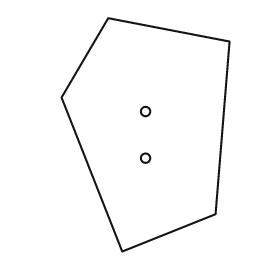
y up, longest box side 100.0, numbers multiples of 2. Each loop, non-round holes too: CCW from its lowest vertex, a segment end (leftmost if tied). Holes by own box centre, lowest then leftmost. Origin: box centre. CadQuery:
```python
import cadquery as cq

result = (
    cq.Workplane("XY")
    .moveTo(-10.0, -50.0)
    .lineTo(30.0, -34.0)
    .lineTo(36.0, 40.0)
    .lineTo(-16.0, 50.0)
    .lineTo(-36.0, 16.0)
    .close()
    .moveTo(0.0, -10.0)
    .circle(2.0)
    .moveTo(0.0, 10.0)
    .circle(2.0)
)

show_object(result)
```